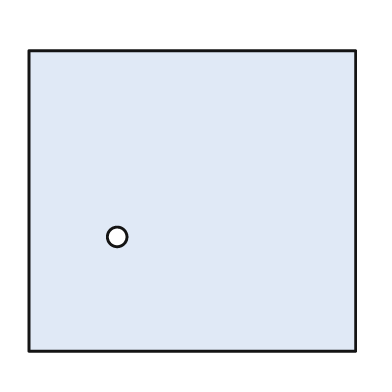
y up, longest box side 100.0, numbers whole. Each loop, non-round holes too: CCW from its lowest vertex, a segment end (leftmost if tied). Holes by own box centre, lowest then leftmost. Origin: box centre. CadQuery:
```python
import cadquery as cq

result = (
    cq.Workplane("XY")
    .moveTo(-50.0, -46.0)
    .lineTo(50.0, -46.0)
    .lineTo(50.0, 46.0)
    .lineTo(-50.0, 46.0)
    .close()
    .moveTo(-23.0, -11.0)
    .circle(3.0)
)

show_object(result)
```